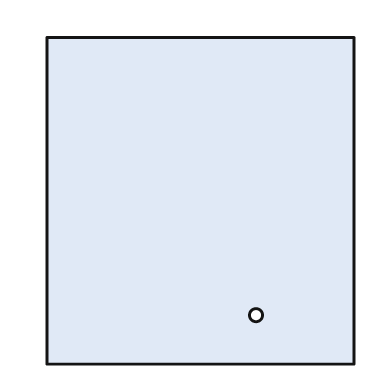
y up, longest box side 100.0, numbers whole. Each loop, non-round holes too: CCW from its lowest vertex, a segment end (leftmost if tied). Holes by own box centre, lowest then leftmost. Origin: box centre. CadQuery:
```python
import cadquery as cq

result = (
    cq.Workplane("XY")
    .moveTo(-47.0, -50.0)
    .lineTo(47.0, -50.0)
    .lineTo(47.0, 50.0)
    .lineTo(-47.0, 50.0)
    .close()
    .moveTo(17.0, -35.0)
    .circle(2.0)
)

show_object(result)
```